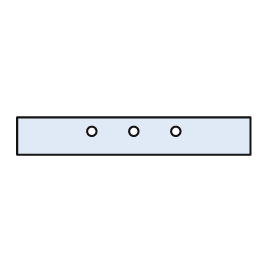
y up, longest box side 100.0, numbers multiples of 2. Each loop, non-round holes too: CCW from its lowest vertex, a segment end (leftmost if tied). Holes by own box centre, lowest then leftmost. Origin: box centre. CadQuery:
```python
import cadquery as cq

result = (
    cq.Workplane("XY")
    .moveTo(-50.0, -8.0)
    .lineTo(50.0, -8.0)
    .lineTo(50.0, 8.0)
    .lineTo(-50.0, 8.0)
    .close()
    .moveTo(-18.0, 2.0)
    .circle(2.0)
    .moveTo(0.0, 2.0)
    .circle(2.0)
    .moveTo(18.0, 2.0)
    .circle(2.0)
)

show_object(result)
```